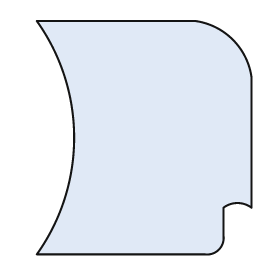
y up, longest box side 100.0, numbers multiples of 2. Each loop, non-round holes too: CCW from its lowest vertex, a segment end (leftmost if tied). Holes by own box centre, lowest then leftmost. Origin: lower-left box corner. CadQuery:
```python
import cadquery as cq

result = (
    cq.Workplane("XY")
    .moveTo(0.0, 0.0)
    .lineTo(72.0, 0.0)
    .threePointArc((78.0, 2.0), (80.0, 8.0))
    .lineTo(80.0, 20.0)
    .threePointArc((86.0, 22.0), (92.0, 20.0))
    .lineTo(92.0, 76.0)
    .threePointArc((84.0, 92.0), (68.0, 100.0))
    .lineTo(0.0, 100.0)
    .threePointArc((16.0, 50.0), (0.0, 0.0))
    .close()
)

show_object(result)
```